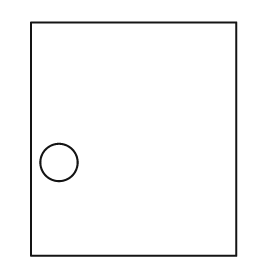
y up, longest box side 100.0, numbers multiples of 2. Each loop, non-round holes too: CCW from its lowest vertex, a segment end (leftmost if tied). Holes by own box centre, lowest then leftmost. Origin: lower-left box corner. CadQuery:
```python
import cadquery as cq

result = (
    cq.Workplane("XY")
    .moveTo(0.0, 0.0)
    .lineTo(88.0, 0.0)
    .lineTo(88.0, 100.0)
    .lineTo(0.0, 100.0)
    .close()
    .moveTo(12.0, 40.0)
    .circle(8.0)
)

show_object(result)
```